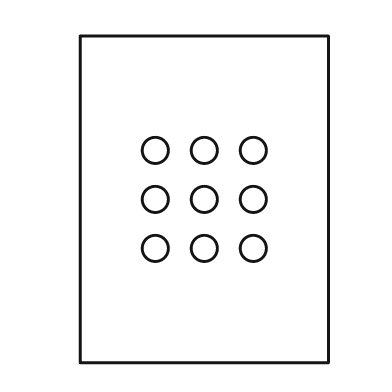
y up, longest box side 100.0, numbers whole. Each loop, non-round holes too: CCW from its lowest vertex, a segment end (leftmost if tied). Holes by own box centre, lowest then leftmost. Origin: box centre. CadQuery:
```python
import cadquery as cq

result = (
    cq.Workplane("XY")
    .moveTo(-38.0, -50.0)
    .lineTo(38.0, -50.0)
    .lineTo(38.0, 50.0)
    .lineTo(-38.0, 50.0)
    .close()
    .moveTo(-15.0, -15.0)
    .circle(4.0)
    .moveTo(0.0, -15.0)
    .circle(4.0)
    .moveTo(15.0, -15.0)
    .circle(4.0)
    .moveTo(-15.0, 0.0)
    .circle(4.0)
    .moveTo(0.0, 0.0)
    .circle(4.0)
    .moveTo(15.0, 0.0)
    .circle(4.0)
    .moveTo(-15.0, 15.0)
    .circle(4.0)
    .moveTo(0.0, 15.0)
    .circle(4.0)
    .moveTo(15.0, 15.0)
    .circle(4.0)
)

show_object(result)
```